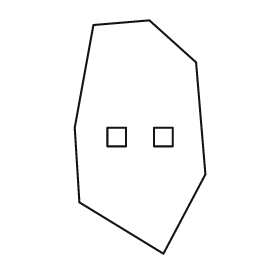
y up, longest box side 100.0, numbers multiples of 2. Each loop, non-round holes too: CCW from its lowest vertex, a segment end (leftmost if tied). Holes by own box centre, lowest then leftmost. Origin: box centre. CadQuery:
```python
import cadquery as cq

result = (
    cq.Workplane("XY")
    .moveTo(10.0, -50.0)
    .lineTo(28.0, -16.0)
    .lineTo(24.0, 32.0)
    .lineTo(4.0, 50.0)
    .lineTo(-20.0, 48.0)
    .lineTo(-28.0, 4.0)
    .lineTo(-26.0, -28.0)
    .close()
    .moveTo(-14.0, -4.0)
    .lineTo(-6.0, -4.0)
    .lineTo(-6.0, 4.0)
    .lineTo(-14.0, 4.0)
    .close()
    .moveTo(6.0, -4.0)
    .lineTo(14.0, -4.0)
    .lineTo(14.0, 4.0)
    .lineTo(6.0, 4.0)
    .close()
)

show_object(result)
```